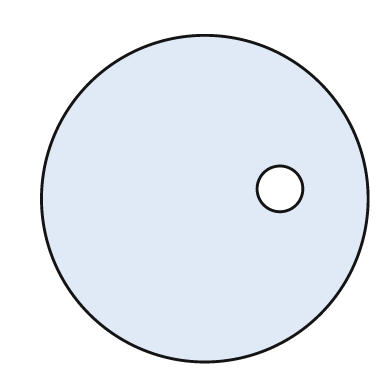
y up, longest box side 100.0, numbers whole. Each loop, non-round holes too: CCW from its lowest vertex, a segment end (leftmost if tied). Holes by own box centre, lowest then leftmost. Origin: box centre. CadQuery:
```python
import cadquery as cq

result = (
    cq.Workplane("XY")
    .moveTo(0.0, 0.0)
    .circle(50.0)
    .moveTo(23.0, 3.0)
    .circle(7.0)
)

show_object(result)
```